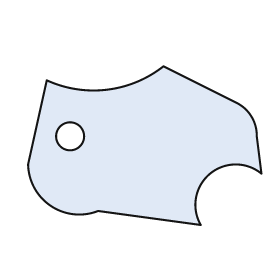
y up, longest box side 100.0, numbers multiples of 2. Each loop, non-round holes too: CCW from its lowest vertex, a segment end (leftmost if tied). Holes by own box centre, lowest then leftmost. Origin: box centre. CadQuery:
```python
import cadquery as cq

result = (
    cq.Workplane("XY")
    .moveTo(24.0, -34.0)
    .threePointArc((28.0, -12.0), (50.0, -12.0))
    .lineTo(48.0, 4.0)
    .threePointArc((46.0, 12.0), (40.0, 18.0))
    .lineTo(8.0, 34.0)
    .threePointArc((-16.0, 24.0), (-42.0, 28.0))
    .lineTo(-50.0, -8.0)
    .threePointArc((-40.0, -26.0), (-20.0, -28.0))
    .close()
    .moveTo(-32.0, 4.0)
    .circle(6.0)
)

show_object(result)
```